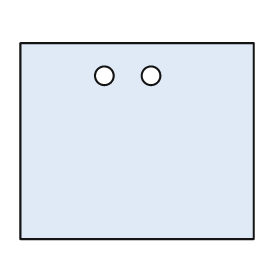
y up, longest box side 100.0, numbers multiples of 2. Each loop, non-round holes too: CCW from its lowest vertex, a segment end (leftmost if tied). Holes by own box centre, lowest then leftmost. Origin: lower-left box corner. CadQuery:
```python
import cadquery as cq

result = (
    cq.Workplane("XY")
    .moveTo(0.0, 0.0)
    .lineTo(100.0, 0.0)
    .lineTo(100.0, 84.0)
    .lineTo(0.0, 84.0)
    .close()
    .moveTo(36.0, 70.0)
    .circle(4.0)
    .moveTo(56.0, 70.0)
    .circle(4.0)
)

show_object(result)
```